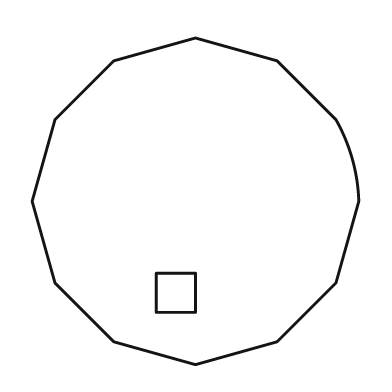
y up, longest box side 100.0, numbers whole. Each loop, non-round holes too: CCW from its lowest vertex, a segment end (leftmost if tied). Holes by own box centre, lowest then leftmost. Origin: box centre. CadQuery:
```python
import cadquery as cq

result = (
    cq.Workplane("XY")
    .moveTo(0.0, -50.0)
    .lineTo(25.0, -43.0)
    .lineTo(43.0, -25.0)
    .lineTo(50.0, 0.0)
    .threePointArc((48.0, 13.0), (43.0, 25.0))
    .lineTo(25.0, 43.0)
    .lineTo(0.0, 50.0)
    .lineTo(-25.0, 43.0)
    .lineTo(-43.0, 25.0)
    .lineTo(-50.0, 0.0)
    .lineTo(-43.0, -25.0)
    .lineTo(-25.0, -43.0)
    .close()
    .moveTo(-12.0, -34.0)
    .lineTo(0.0, -34.0)
    .lineTo(0.0, -22.0)
    .lineTo(-12.0, -22.0)
    .close()
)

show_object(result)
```